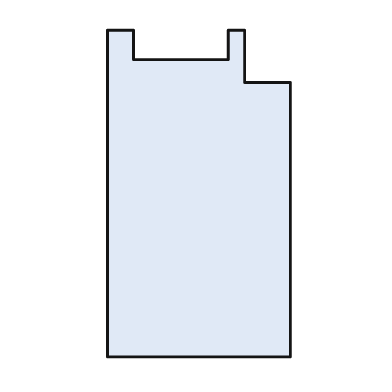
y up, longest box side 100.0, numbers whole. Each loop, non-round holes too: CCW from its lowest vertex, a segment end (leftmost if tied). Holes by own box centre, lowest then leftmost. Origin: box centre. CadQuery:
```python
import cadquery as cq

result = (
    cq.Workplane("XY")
    .moveTo(-28.0, -50.0)
    .lineTo(28.0, -50.0)
    .lineTo(28.0, 34.0)
    .lineTo(14.0, 34.0)
    .lineTo(14.0, 50.0)
    .lineTo(9.0, 50.0)
    .lineTo(9.0, 41.0)
    .lineTo(-20.0, 41.0)
    .lineTo(-20.0, 50.0)
    .lineTo(-28.0, 50.0)
    .close()
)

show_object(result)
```